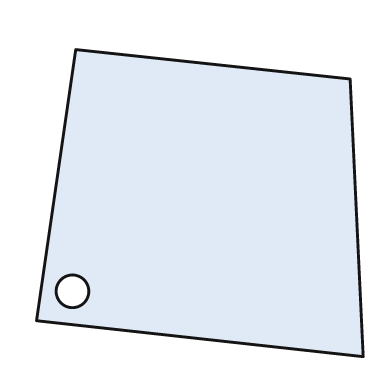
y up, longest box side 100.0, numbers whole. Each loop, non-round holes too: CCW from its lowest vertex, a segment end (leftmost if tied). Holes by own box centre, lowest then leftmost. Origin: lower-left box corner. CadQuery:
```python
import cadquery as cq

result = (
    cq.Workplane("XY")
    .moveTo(100.0, 0.0)
    .lineTo(96.0, 85.0)
    .lineTo(12.0, 94.0)
    .lineTo(0.0, 11.0)
    .close()
    .moveTo(11.0, 20.0)
    .circle(5.0)
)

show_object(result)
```